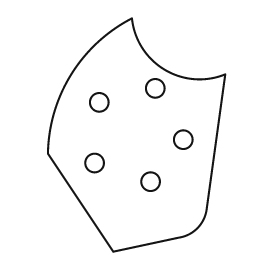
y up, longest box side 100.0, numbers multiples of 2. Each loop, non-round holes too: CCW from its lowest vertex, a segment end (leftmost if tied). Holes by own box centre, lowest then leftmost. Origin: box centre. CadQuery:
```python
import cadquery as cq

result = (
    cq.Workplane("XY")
    .moveTo(-10.0, -50.0)
    .lineTo(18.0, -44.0)
    .threePointArc((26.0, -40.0), (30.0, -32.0))
    .lineTo(38.0, 26.0)
    .threePointArc((12.0, 28.0), (-2.0, 50.0))
    .threePointArc((-28.0, 26.0), (-38.0, -8.0))
    .close()
    .moveTo(6.0, -20.0)
    .circle(4.0)
    .moveTo(-18.0, -12.0)
    .circle(4.0)
    .moveTo(20.0, -2.0)
    .circle(4.0)
    .moveTo(-16.0, 14.0)
    .circle(4.0)
    .moveTo(8.0, 20.0)
    .circle(4.0)
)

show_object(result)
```